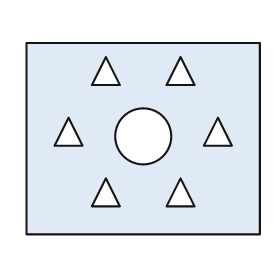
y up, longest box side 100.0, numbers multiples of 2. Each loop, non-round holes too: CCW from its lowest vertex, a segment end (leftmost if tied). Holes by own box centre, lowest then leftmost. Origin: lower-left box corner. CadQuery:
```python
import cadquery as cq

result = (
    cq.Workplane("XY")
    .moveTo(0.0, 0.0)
    .lineTo(100.0, 0.0)
    .lineTo(100.0, 82.0)
    .lineTo(0.0, 82.0)
    .close()
    .moveTo(28.0, 12.0)
    .lineTo(40.0, 12.0)
    .lineTo(34.0, 24.0)
    .close()
    .moveTo(60.0, 12.0)
    .lineTo(72.0, 12.0)
    .lineTo(66.0, 24.0)
    .close()
    .moveTo(50.0, 42.0)
    .circle(12.0)
    .moveTo(12.0, 38.0)
    .lineTo(24.0, 38.0)
    .lineTo(18.0, 50.0)
    .close()
    .moveTo(76.0, 38.0)
    .lineTo(88.0, 38.0)
    .lineTo(82.0, 50.0)
    .close()
    .moveTo(28.0, 64.0)
    .lineTo(40.0, 64.0)
    .lineTo(34.0, 76.0)
    .close()
    .moveTo(60.0, 64.0)
    .lineTo(72.0, 64.0)
    .lineTo(66.0, 76.0)
    .close()
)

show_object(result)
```